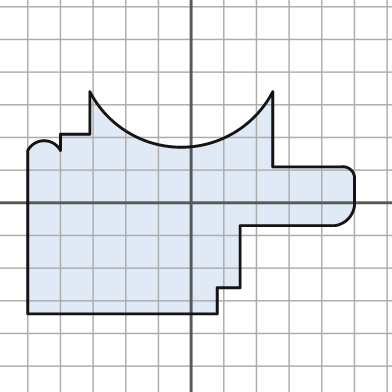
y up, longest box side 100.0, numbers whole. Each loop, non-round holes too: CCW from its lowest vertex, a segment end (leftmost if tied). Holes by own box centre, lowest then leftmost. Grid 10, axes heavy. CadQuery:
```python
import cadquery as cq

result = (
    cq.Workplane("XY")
    .moveTo(-50.0, -34.0)
    .lineTo(8.0, -34.0)
    .lineTo(8.0, -26.0)
    .lineTo(15.0, -26.0)
    .lineTo(15.0, -7.0)
    .lineTo(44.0, -7.0)
    .threePointArc((48.0, -5.0), (50.0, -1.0))
    .lineTo(50.0, 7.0)
    .threePointArc((49.0, 10.0), (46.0, 11.0))
    .lineTo(25.0, 11.0)
    .lineTo(25.0, 34.0)
    .threePointArc((-3.0, 17.0), (-31.0, 34.0))
    .lineTo(-31.0, 21.0)
    .lineTo(-40.0, 21.0)
    .lineTo(-40.0, 16.0)
    .threePointArc((-45.0, 19.0), (-50.0, 16.0))
    .close()
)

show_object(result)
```